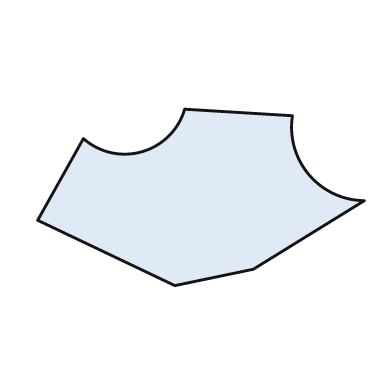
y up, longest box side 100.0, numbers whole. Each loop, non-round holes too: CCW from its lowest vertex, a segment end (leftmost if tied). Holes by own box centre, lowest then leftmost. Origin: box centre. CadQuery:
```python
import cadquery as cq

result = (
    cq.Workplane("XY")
    .moveTo(-8.0, -27.0)
    .lineTo(16.0, -22.0)
    .lineTo(50.0, -1.0)
    .threePointArc((33.0, 7.0), (28.0, 25.0))
    .lineTo(-5.0, 27.0)
    .threePointArc((-18.0, 14.0), (-36.0, 18.0))
    .lineTo(-50.0, -7.0)
    .close()
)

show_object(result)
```